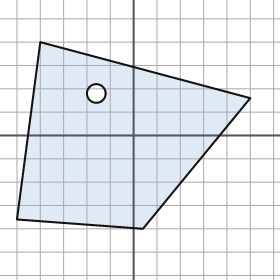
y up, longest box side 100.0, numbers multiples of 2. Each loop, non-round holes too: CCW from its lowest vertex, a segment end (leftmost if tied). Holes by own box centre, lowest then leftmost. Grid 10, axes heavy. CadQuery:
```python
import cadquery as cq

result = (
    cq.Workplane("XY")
    .moveTo(4.0, -40.0)
    .lineTo(50.0, 16.0)
    .lineTo(-40.0, 40.0)
    .lineTo(-50.0, -36.0)
    .close()
    .moveTo(-16.0, 18.0)
    .circle(4.0)
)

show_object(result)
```